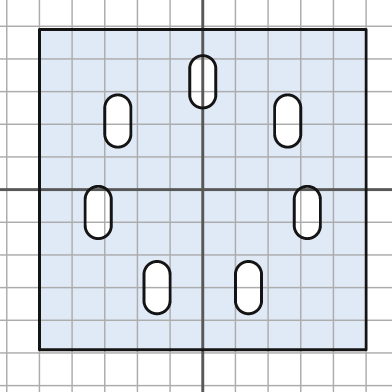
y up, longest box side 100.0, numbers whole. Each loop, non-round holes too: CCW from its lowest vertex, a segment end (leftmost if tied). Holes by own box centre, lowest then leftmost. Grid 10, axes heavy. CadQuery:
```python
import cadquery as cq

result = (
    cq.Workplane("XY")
    .moveTo(-50.0, -49.0)
    .lineTo(50.0, -49.0)
    .lineTo(50.0, 49.0)
    .lineTo(-50.0, 49.0)
    .close()
    .moveTo(-18.0, -34.0)
    .threePointArc((-14.0, -38.0), (-10.0, -34.0))
    .lineTo(-10.0, -26.0)
    .threePointArc((-14.0, -22.0), (-18.0, -26.0))
    .close()
    .moveTo(10.0, -34.0)
    .threePointArc((14.0, -38.0), (18.0, -34.0))
    .lineTo(18.0, -26.0)
    .threePointArc((14.0, -22.0), (10.0, -26.0))
    .close()
    .moveTo(-36.0, -11.0)
    .threePointArc((-32.0, -15.0), (-28.0, -11.0))
    .lineTo(-28.0, -3.0)
    .threePointArc((-32.0, 1.0), (-36.0, -3.0))
    .close()
    .moveTo(28.0, -11.0)
    .threePointArc((32.0, -15.0), (36.0, -11.0))
    .lineTo(36.0, -3.0)
    .threePointArc((32.0, 1.0), (28.0, -3.0))
    .close()
    .moveTo(-30.0, 17.0)
    .threePointArc((-26.0, 13.0), (-22.0, 17.0))
    .lineTo(-22.0, 25.0)
    .threePointArc((-26.0, 29.0), (-30.0, 25.0))
    .close()
    .moveTo(22.0, 17.0)
    .threePointArc((26.0, 13.0), (30.0, 17.0))
    .lineTo(30.0, 25.0)
    .threePointArc((26.0, 29.0), (22.0, 25.0))
    .close()
    .moveTo(-4.0, 29.0)
    .threePointArc((0.0, 25.0), (4.0, 29.0))
    .lineTo(4.0, 37.0)
    .threePointArc((0.0, 41.0), (-4.0, 37.0))
    .close()
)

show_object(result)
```